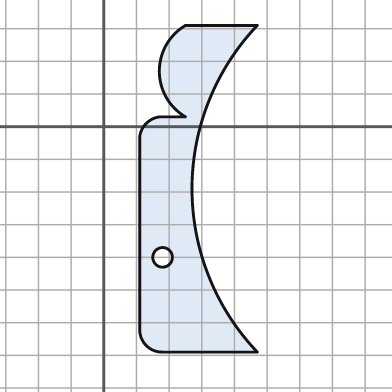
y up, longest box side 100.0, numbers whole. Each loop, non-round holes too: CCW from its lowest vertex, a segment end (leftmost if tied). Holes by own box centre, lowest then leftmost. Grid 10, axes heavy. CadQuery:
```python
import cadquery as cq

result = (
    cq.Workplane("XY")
    .moveTo(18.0, -69.0)
    .lineTo(47.0, -69.0)
    .threePointArc((27.0, -19.0), (47.0, 31.0))
    .lineTo(25.0, 31.0)
    .threePointArc((17.0, 17.0), (25.0, 3.0))
    .lineTo(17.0, 3.0)
    .threePointArc((13.0, 1.0), (11.0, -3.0))
    .lineTo(11.0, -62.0)
    .threePointArc((13.0, -67.0), (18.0, -69.0))
    .close()
    .moveTo(18.0, -40.0)
    .circle(3.0)
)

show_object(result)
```